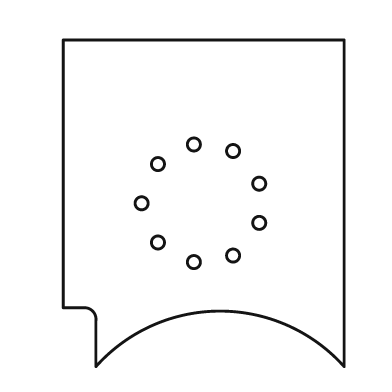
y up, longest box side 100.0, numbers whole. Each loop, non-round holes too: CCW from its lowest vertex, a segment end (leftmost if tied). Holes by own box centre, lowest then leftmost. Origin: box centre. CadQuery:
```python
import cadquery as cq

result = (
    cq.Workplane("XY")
    .moveTo(-33.0, -50.0)
    .threePointArc((5.0, -33.0), (43.0, -50.0))
    .lineTo(43.0, 50.0)
    .lineTo(-43.0, 50.0)
    .lineTo(-43.0, -32.0)
    .lineTo(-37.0, -32.0)
    .threePointArc((-34.0, -33.0), (-33.0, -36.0))
    .close()
    .moveTo(-3.0, -18.0)
    .circle(2.0)
    .moveTo(9.0, -16.0)
    .circle(2.0)
    .moveTo(-14.0, -12.0)
    .circle(2.0)
    .moveTo(17.0, -6.0)
    .circle(2.0)
    .moveTo(-19.0, 0.0)
    .circle(2.0)
    .moveTo(17.0, 6.0)
    .circle(2.0)
    .moveTo(-14.0, 12.0)
    .circle(2.0)
    .moveTo(9.0, 16.0)
    .circle(2.0)
    .moveTo(-3.0, 18.0)
    .circle(2.0)
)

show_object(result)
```